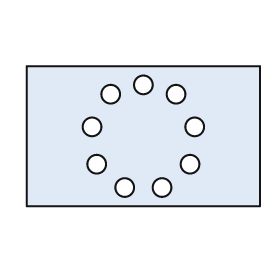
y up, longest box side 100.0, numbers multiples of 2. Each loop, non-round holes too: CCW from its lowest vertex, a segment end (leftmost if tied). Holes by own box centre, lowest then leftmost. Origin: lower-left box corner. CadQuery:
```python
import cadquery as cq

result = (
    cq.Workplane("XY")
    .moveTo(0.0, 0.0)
    .lineTo(100.0, 0.0)
    .lineTo(100.0, 60.0)
    .lineTo(0.0, 60.0)
    .close()
    .moveTo(42.0, 8.0)
    .circle(4.0)
    .moveTo(58.0, 8.0)
    .circle(4.0)
    .moveTo(30.0, 18.0)
    .circle(4.0)
    .moveTo(70.0, 18.0)
    .circle(4.0)
    .moveTo(28.0, 34.0)
    .circle(4.0)
    .moveTo(72.0, 34.0)
    .circle(4.0)
    .moveTo(36.0, 48.0)
    .circle(4.0)
    .moveTo(64.0, 48.0)
    .circle(4.0)
    .moveTo(50.0, 52.0)
    .circle(4.0)
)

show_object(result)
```